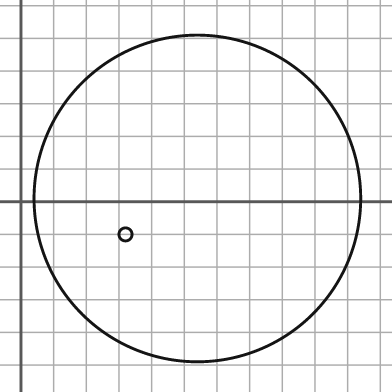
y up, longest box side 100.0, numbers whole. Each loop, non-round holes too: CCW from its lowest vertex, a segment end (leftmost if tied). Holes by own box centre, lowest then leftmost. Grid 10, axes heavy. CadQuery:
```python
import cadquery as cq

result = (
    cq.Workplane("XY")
    .moveTo(54.0, 1.0)
    .circle(50.0)
    .moveTo(32.0, -10.0)
    .circle(2.0)
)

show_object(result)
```